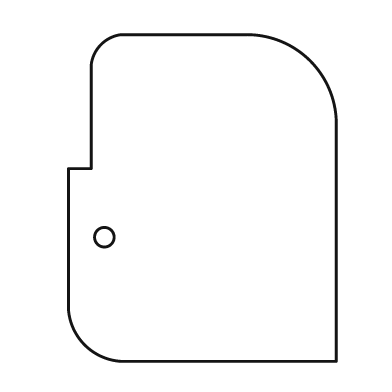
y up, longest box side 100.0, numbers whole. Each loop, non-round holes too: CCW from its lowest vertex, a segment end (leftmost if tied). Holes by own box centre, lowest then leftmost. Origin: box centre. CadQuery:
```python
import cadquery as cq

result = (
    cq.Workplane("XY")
    .moveTo(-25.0, -50.0)
    .lineTo(41.0, -50.0)
    .lineTo(41.0, 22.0)
    .threePointArc((33.0, 42.0), (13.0, 50.0))
    .lineTo(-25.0, 50.0)
    .threePointArc((-31.0, 47.0), (-34.0, 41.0))
    .lineTo(-34.0, 9.0)
    .lineTo(-41.0, 9.0)
    .lineTo(-41.0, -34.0)
    .threePointArc((-36.0, -45.0), (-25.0, -50.0))
    .close()
    .moveTo(-30.0, -12.0)
    .circle(3.0)
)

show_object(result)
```